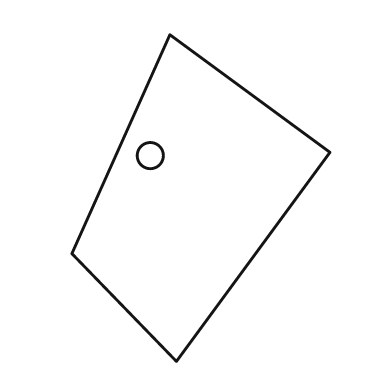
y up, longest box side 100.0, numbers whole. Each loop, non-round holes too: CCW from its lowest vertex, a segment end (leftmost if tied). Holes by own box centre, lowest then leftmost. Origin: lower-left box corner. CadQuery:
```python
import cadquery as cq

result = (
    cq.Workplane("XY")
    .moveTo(32.0, 0.0)
    .lineTo(79.0, 64.0)
    .lineTo(30.0, 100.0)
    .lineTo(0.0, 33.0)
    .close()
    .moveTo(24.0, 63.0)
    .circle(4.0)
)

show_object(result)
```